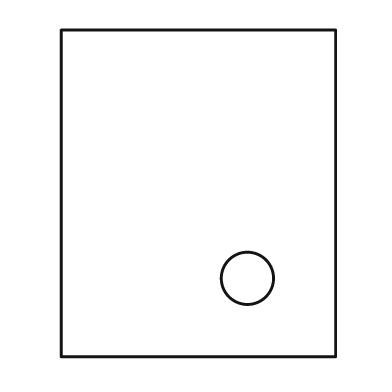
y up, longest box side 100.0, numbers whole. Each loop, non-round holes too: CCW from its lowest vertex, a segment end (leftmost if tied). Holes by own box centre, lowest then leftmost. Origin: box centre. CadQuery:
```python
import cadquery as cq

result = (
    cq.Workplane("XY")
    .moveTo(-42.0, -50.0)
    .lineTo(42.0, -50.0)
    .lineTo(42.0, 50.0)
    .lineTo(-42.0, 50.0)
    .close()
    .moveTo(15.0, -26.0)
    .circle(8.0)
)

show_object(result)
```